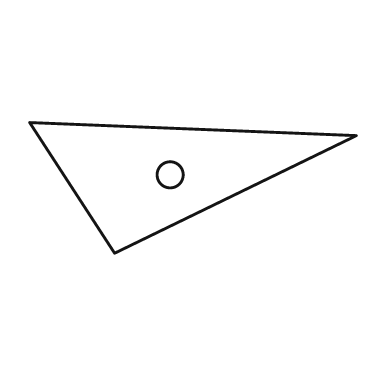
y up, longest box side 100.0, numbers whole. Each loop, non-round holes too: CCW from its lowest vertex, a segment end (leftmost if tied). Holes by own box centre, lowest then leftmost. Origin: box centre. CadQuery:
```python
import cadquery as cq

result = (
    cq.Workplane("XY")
    .moveTo(-24.0, -20.0)
    .lineTo(50.0, 16.0)
    .lineTo(-50.0, 20.0)
    .close()
    .moveTo(-7.0, 4.0)
    .circle(4.0)
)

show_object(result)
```